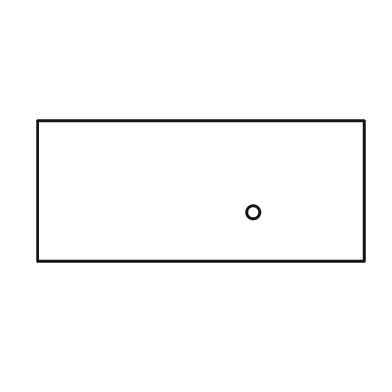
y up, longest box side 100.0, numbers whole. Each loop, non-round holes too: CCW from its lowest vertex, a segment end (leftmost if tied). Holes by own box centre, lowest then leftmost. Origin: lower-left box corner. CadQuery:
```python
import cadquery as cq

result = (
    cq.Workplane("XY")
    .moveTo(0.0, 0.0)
    .lineTo(100.0, 0.0)
    .lineTo(100.0, 43.0)
    .lineTo(0.0, 43.0)
    .close()
    .moveTo(66.0, 15.0)
    .circle(2.0)
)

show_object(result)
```